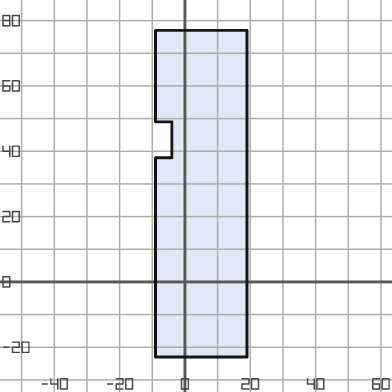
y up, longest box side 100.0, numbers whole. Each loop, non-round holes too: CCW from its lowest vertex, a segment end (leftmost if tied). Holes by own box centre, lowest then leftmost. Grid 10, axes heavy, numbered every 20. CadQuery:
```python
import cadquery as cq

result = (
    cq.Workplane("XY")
    .moveTo(-9.0, -23.0)
    .lineTo(19.0, -23.0)
    .lineTo(19.0, 77.0)
    .lineTo(-9.0, 77.0)
    .lineTo(-9.0, 49.0)
    .lineTo(-4.0, 49.0)
    .lineTo(-4.0, 38.0)
    .lineTo(-9.0, 38.0)
    .close()
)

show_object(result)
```